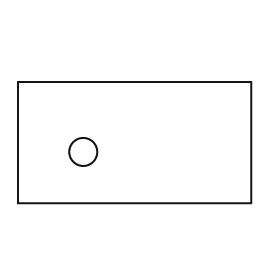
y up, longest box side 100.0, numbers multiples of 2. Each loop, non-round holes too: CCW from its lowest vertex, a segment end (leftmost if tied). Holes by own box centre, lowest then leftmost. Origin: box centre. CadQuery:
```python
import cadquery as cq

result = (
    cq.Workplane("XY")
    .moveTo(-50.0, -26.0)
    .lineTo(50.0, -26.0)
    .lineTo(50.0, 26.0)
    .lineTo(-50.0, 26.0)
    .close()
    .moveTo(-22.0, -4.0)
    .circle(6.0)
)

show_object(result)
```